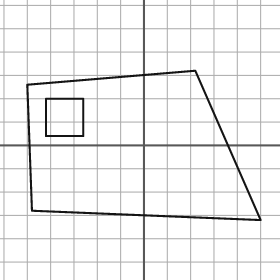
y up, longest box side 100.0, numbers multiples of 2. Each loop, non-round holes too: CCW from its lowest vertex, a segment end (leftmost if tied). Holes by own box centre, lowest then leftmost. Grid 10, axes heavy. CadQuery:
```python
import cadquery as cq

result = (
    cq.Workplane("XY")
    .moveTo(50.0, -32.0)
    .lineTo(22.0, 32.0)
    .lineTo(-50.0, 26.0)
    .lineTo(-48.0, -28.0)
    .close()
    .moveTo(-42.0, 4.0)
    .lineTo(-26.0, 4.0)
    .lineTo(-26.0, 20.0)
    .lineTo(-42.0, 20.0)
    .close()
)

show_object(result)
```